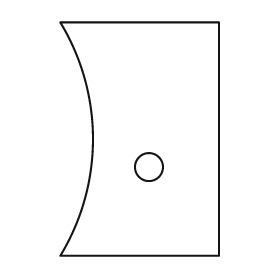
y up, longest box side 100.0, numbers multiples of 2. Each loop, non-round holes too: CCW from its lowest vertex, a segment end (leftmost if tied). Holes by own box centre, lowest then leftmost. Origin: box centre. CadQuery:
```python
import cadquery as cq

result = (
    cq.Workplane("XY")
    .moveTo(-34.0, -50.0)
    .lineTo(34.0, -50.0)
    .lineTo(34.0, 50.0)
    .lineTo(-34.0, 50.0)
    .threePointArc((-20.0, 0.0), (-34.0, -50.0))
    .close()
    .moveTo(4.0, -12.0)
    .circle(6.0)
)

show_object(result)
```